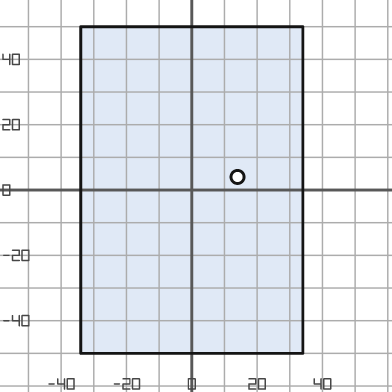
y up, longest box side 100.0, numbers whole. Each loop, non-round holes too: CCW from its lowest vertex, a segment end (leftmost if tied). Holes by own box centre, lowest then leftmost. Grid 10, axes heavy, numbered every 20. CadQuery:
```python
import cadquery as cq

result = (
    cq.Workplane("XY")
    .moveTo(-34.0, -50.0)
    .lineTo(34.0, -50.0)
    .lineTo(34.0, 50.0)
    .lineTo(-34.0, 50.0)
    .close()
    .moveTo(14.0, 4.0)
    .circle(2.0)
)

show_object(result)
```